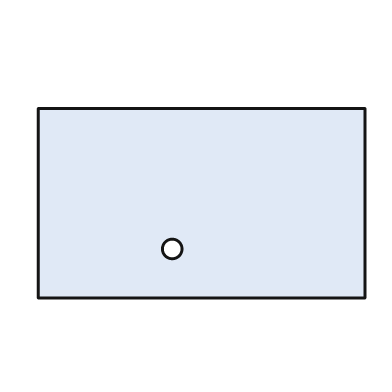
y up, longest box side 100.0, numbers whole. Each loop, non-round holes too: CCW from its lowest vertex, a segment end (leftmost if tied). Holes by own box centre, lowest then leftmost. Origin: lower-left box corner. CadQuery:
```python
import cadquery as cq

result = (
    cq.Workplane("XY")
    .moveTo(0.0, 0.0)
    .lineTo(100.0, 0.0)
    .lineTo(100.0, 58.0)
    .lineTo(0.0, 58.0)
    .close()
    .moveTo(41.0, 15.0)
    .circle(3.0)
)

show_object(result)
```